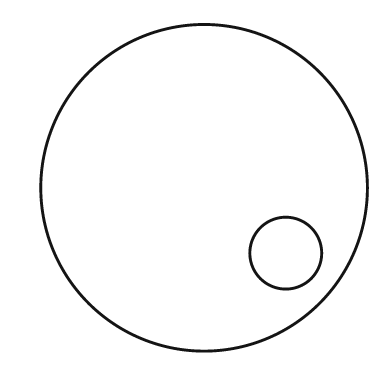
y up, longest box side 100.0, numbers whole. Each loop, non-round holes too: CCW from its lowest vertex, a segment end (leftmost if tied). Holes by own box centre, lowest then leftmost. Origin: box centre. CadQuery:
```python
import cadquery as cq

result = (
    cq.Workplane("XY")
    .moveTo(0.0, 0.0)
    .circle(50.0)
    .moveTo(25.0, -20.0)
    .circle(11.0)
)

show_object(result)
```